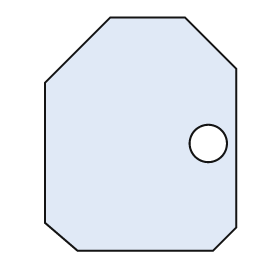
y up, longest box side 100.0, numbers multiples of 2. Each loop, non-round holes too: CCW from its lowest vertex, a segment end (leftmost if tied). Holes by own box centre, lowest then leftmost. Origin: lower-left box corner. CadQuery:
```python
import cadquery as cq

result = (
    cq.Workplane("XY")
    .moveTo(14.0, 0.0)
    .lineTo(72.0, 0.0)
    .lineTo(82.0, 10.0)
    .lineTo(82.0, 78.0)
    .lineTo(60.0, 100.0)
    .lineTo(28.0, 100.0)
    .lineTo(0.0, 72.0)
    .lineTo(0.0, 12.0)
    .close()
    .moveTo(70.0, 46.0)
    .circle(8.0)
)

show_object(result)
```